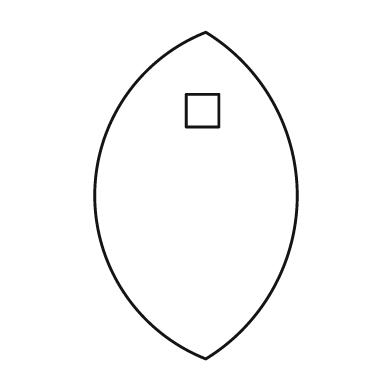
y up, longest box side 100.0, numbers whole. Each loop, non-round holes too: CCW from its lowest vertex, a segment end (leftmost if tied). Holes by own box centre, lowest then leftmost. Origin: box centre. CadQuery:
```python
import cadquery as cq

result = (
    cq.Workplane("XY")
    .moveTo(3.0, -50.0)
    .threePointArc((31.0, 0.0), (3.0, 50.0))
    .threePointArc((-31.0, 0.0), (3.0, -50.0))
    .close()
    .moveTo(-3.0, 21.0)
    .lineTo(7.0, 21.0)
    .lineTo(7.0, 31.0)
    .lineTo(-3.0, 31.0)
    .close()
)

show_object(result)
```